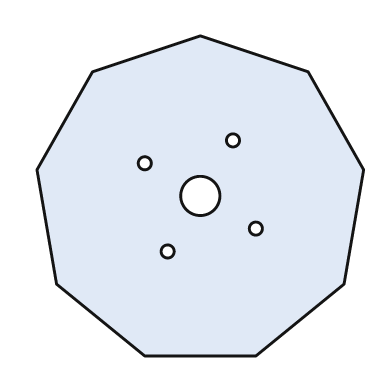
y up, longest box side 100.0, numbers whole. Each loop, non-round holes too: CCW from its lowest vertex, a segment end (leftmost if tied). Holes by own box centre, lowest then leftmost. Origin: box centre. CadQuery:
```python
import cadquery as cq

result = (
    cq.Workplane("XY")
    .moveTo(-17.0, -49.0)
    .lineTo(17.0, -49.0)
    .lineTo(44.0, -27.0)
    .lineTo(50.0, 8.0)
    .lineTo(33.0, 38.0)
    .lineTo(0.0, 49.0)
    .lineTo(-33.0, 38.0)
    .lineTo(-50.0, 8.0)
    .lineTo(-44.0, -27.0)
    .close()
    .moveTo(-10.0, -17.0)
    .circle(2.0)
    .moveTo(17.0, -10.0)
    .circle(2.0)
    .moveTo(0.0, 0.0)
    .circle(6.0)
    .moveTo(-17.0, 10.0)
    .circle(2.0)
    .moveTo(10.0, 17.0)
    .circle(2.0)
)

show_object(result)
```